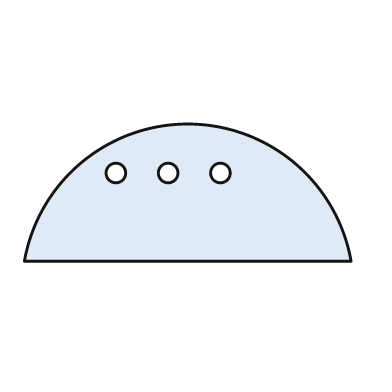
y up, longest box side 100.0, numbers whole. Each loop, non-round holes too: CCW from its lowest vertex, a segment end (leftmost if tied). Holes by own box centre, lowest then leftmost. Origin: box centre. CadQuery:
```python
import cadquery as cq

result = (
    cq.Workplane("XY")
    .moveTo(-50.0, -21.0)
    .lineTo(50.0, -21.0)
    .threePointArc((0.0, 21.0), (-50.0, -21.0))
    .close()
    .moveTo(-22.0, 6.0)
    .circle(3.0)
    .moveTo(-6.0, 6.0)
    .circle(3.0)
    .moveTo(10.0, 6.0)
    .circle(3.0)
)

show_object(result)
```